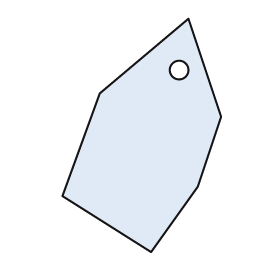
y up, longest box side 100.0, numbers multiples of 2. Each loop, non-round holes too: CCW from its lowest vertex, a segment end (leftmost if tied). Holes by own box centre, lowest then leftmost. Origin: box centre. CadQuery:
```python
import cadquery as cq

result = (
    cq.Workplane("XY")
    .moveTo(4.0, -50.0)
    .lineTo(24.0, -22.0)
    .lineTo(34.0, 8.0)
    .lineTo(20.0, 50.0)
    .lineTo(-18.0, 18.0)
    .lineTo(-34.0, -26.0)
    .close()
    .moveTo(16.0, 28.0)
    .circle(4.0)
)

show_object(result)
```